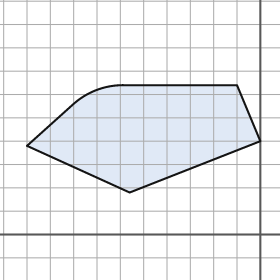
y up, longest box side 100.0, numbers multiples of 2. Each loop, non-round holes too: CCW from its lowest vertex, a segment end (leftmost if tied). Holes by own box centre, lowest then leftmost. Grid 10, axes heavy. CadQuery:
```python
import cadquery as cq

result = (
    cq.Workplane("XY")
    .moveTo(-56.0, 18.0)
    .lineTo(0.0, 40.0)
    .lineTo(-10.0, 64.0)
    .lineTo(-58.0, 64.0)
    .threePointArc((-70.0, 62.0), (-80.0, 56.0))
    .lineTo(-100.0, 38.0)
    .close()
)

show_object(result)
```